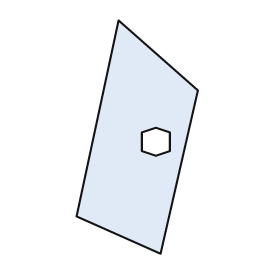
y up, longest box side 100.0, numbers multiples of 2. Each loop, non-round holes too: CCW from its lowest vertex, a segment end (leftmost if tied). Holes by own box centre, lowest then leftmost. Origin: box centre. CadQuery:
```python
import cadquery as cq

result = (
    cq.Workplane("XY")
    .moveTo(10.0, -50.0)
    .lineTo(26.0, 20.0)
    .lineTo(-8.0, 50.0)
    .lineTo(-26.0, -34.0)
    .close()
    .moveTo(8.0, -8.0)
    .lineTo(14.0, -6.0)
    .lineTo(14.0, 2.0)
    .lineTo(8.0, 4.0)
    .lineTo(2.0, 2.0)
    .lineTo(2.0, -6.0)
    .close()
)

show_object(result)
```